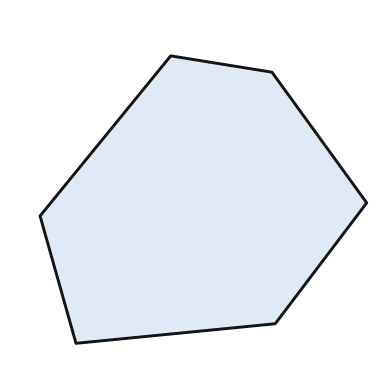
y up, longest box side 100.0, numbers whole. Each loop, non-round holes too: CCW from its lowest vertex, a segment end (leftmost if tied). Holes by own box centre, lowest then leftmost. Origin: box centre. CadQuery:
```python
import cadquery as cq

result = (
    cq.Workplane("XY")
    .moveTo(-39.0, -44.0)
    .lineTo(22.0, -38.0)
    .lineTo(50.0, -1.0)
    .lineTo(21.0, 39.0)
    .lineTo(-10.0, 44.0)
    .lineTo(-50.0, -5.0)
    .close()
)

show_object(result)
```